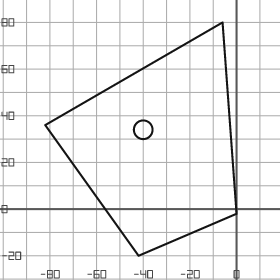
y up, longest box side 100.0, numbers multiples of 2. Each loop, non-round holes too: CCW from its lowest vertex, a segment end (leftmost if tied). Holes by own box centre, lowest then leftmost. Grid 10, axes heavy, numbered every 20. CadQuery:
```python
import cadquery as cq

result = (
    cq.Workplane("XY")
    .moveTo(-42.0, -20.0)
    .lineTo(0.0, -2.0)
    .lineTo(-6.0, 80.0)
    .lineTo(-82.0, 36.0)
    .close()
    .moveTo(-40.0, 34.0)
    .circle(4.0)
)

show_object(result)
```